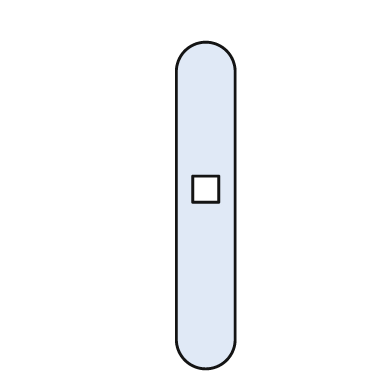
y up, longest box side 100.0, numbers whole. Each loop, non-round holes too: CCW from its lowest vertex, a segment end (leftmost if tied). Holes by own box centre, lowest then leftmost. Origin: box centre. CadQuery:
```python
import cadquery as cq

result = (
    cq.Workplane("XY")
    .moveTo(-9.0, -41.0)
    .threePointArc((0.0, -50.0), (9.0, -41.0))
    .lineTo(9.0, 41.0)
    .threePointArc((0.0, 50.0), (-9.0, 41.0))
    .close()
    .moveTo(-4.0, 1.0)
    .lineTo(4.0, 1.0)
    .lineTo(4.0, 9.0)
    .lineTo(-4.0, 9.0)
    .close()
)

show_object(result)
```